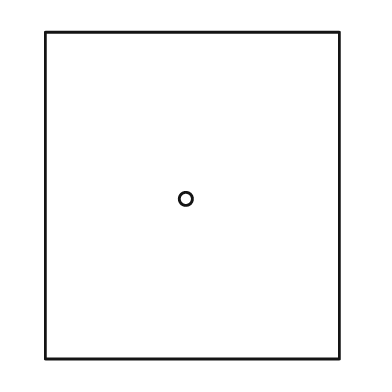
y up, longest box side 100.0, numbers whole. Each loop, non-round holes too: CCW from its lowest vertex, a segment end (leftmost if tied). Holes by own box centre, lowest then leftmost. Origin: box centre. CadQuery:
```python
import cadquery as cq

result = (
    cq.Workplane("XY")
    .moveTo(-45.0, -50.0)
    .lineTo(45.0, -50.0)
    .lineTo(45.0, 50.0)
    .lineTo(-45.0, 50.0)
    .close()
    .moveTo(-2.0, -1.0)
    .circle(2.0)
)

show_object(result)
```